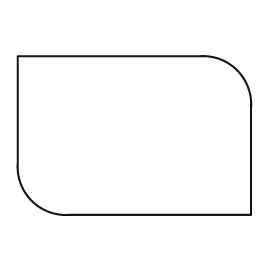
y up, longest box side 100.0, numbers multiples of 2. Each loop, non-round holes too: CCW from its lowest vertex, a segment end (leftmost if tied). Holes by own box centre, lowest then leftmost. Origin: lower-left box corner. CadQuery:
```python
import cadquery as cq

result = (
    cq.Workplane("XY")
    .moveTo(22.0, 0.0)
    .lineTo(100.0, 0.0)
    .lineTo(100.0, 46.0)
    .threePointArc((94.0, 62.0), (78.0, 68.0))
    .lineTo(0.0, 68.0)
    .lineTo(0.0, 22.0)
    .threePointArc((6.0, 6.0), (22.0, 0.0))
    .close()
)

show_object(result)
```